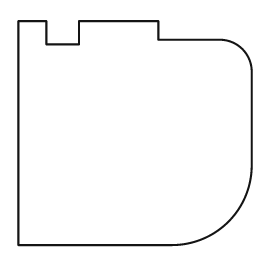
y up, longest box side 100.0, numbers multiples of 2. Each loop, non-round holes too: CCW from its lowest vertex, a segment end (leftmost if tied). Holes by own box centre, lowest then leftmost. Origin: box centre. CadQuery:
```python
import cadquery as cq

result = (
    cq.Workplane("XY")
    .moveTo(-50.0, -48.0)
    .lineTo(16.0, -48.0)
    .threePointArc((40.0, -38.0), (50.0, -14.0))
    .lineTo(50.0, 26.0)
    .threePointArc((46.0, 36.0), (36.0, 40.0))
    .lineTo(10.0, 40.0)
    .lineTo(10.0, 48.0)
    .lineTo(-24.0, 48.0)
    .lineTo(-24.0, 38.0)
    .lineTo(-38.0, 38.0)
    .lineTo(-38.0, 48.0)
    .lineTo(-50.0, 48.0)
    .close()
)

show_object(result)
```